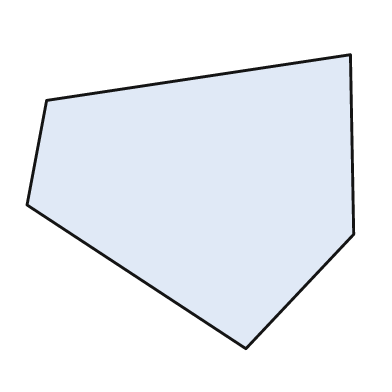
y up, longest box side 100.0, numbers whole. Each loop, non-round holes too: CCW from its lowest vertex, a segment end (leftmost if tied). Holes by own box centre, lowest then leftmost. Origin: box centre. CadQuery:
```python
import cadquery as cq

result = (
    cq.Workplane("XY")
    .moveTo(17.0, -45.0)
    .lineTo(50.0, -10.0)
    .lineTo(49.0, 45.0)
    .lineTo(-44.0, 31.0)
    .lineTo(-50.0, -1.0)
    .close()
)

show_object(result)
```